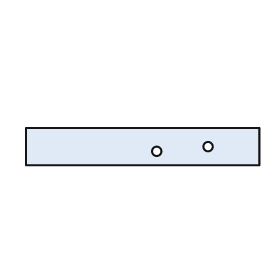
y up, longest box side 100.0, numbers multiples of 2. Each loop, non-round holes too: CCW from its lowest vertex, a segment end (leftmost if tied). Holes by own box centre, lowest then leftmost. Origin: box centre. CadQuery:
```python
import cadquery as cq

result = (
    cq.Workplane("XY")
    .moveTo(-50.0, -8.0)
    .lineTo(50.0, -8.0)
    .lineTo(50.0, 8.0)
    .lineTo(-50.0, 8.0)
    .close()
    .moveTo(6.0, -2.0)
    .circle(2.0)
    .moveTo(28.0, 0.0)
    .circle(2.0)
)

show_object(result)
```